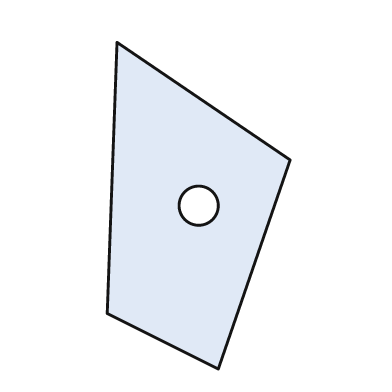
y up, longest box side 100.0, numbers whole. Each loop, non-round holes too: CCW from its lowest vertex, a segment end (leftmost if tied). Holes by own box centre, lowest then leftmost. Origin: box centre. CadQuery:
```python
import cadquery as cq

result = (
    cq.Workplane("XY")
    .moveTo(6.0, -50.0)
    .lineTo(28.0, 14.0)
    .lineTo(-25.0, 50.0)
    .lineTo(-28.0, -33.0)
    .close()
    .moveTo(0.0, 0.0)
    .circle(6.0)
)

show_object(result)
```